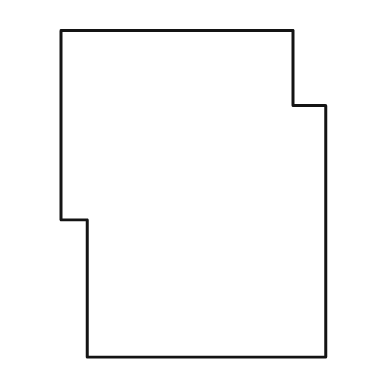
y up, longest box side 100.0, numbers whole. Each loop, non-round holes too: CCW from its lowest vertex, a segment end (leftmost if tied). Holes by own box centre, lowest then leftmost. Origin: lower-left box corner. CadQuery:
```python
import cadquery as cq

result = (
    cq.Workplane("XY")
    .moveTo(8.0, 0.0)
    .lineTo(81.0, 0.0)
    .lineTo(81.0, 77.0)
    .lineTo(71.0, 77.0)
    .lineTo(71.0, 100.0)
    .lineTo(0.0, 100.0)
    .lineTo(0.0, 42.0)
    .lineTo(8.0, 42.0)
    .close()
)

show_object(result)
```